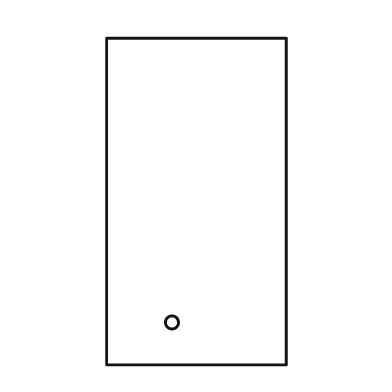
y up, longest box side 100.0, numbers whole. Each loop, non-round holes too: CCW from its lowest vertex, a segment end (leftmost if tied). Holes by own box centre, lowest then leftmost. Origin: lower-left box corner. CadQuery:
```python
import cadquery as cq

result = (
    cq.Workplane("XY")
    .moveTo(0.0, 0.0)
    .lineTo(55.0, 0.0)
    .lineTo(55.0, 100.0)
    .lineTo(0.0, 100.0)
    .close()
    .moveTo(20.0, 13.0)
    .circle(2.0)
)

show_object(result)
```